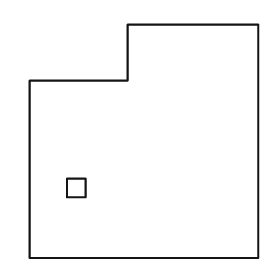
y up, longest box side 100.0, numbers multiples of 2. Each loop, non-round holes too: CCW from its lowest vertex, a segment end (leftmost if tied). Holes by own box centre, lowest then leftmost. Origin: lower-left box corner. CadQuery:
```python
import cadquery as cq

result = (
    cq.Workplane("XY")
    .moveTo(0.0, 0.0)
    .lineTo(98.0, 0.0)
    .lineTo(98.0, 100.0)
    .lineTo(42.0, 100.0)
    .lineTo(42.0, 76.0)
    .lineTo(0.0, 76.0)
    .close()
    .moveTo(16.0, 26.0)
    .lineTo(24.0, 26.0)
    .lineTo(24.0, 34.0)
    .lineTo(16.0, 34.0)
    .close()
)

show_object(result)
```